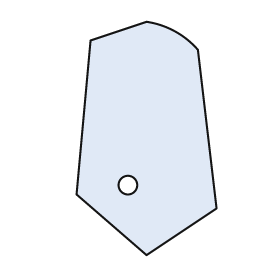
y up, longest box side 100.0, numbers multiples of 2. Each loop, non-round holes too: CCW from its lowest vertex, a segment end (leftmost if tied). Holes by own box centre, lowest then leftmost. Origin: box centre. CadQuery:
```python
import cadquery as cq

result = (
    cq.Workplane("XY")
    .moveTo(0.0, -50.0)
    .lineTo(30.0, -30.0)
    .lineTo(22.0, 38.0)
    .threePointArc((12.0, 46.0), (0.0, 50.0))
    .lineTo(-24.0, 42.0)
    .lineTo(-30.0, -24.0)
    .close()
    .moveTo(-8.0, -20.0)
    .circle(4.0)
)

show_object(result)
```